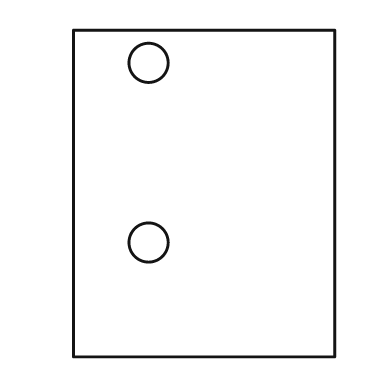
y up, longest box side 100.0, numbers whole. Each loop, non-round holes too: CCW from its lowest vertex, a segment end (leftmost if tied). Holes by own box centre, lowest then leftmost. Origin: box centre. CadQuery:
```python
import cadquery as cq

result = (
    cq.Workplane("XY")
    .moveTo(-40.0, -50.0)
    .lineTo(40.0, -50.0)
    .lineTo(40.0, 50.0)
    .lineTo(-40.0, 50.0)
    .close()
    .moveTo(-17.0, -15.0)
    .circle(6.0)
    .moveTo(-17.0, 40.0)
    .circle(6.0)
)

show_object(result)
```